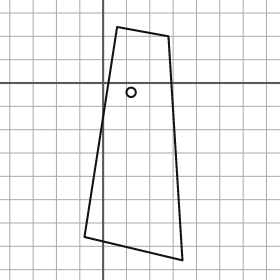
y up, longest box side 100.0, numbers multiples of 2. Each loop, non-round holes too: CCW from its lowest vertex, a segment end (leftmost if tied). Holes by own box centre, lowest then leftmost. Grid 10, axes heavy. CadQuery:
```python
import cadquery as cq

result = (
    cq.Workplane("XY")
    .moveTo(34.0, -76.0)
    .lineTo(28.0, 20.0)
    .lineTo(6.0, 24.0)
    .lineTo(-8.0, -66.0)
    .close()
    .moveTo(12.0, -4.0)
    .circle(2.0)
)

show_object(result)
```